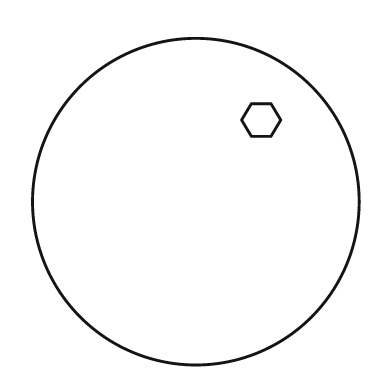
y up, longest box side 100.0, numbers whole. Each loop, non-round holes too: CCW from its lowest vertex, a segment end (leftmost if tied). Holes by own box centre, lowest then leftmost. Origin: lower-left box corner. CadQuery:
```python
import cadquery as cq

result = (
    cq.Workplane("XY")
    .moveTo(50.0, 50.0)
    .circle(50.0)
    .moveTo(67.0, 70.0)
    .lineTo(73.0, 70.0)
    .lineTo(76.0, 75.0)
    .lineTo(73.0, 80.0)
    .lineTo(67.0, 80.0)
    .lineTo(64.0, 75.0)
    .close()
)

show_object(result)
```